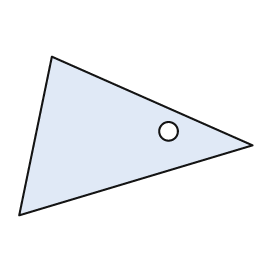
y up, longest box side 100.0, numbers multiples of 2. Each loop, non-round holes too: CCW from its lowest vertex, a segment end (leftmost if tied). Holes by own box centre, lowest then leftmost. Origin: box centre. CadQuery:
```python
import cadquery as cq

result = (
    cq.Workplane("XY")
    .moveTo(-50.0, -34.0)
    .lineTo(50.0, -4.0)
    .lineTo(-36.0, 34.0)
    .close()
    .moveTo(14.0, 2.0)
    .circle(4.0)
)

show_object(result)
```